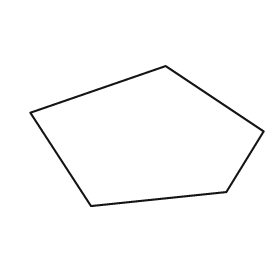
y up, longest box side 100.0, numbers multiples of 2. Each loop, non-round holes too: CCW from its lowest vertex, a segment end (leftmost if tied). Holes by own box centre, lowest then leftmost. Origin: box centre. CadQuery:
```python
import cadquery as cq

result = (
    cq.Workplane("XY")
    .moveTo(-24.0, -30.0)
    .lineTo(34.0, -24.0)
    .lineTo(50.0, 2.0)
    .lineTo(8.0, 30.0)
    .lineTo(-50.0, 10.0)
    .close()
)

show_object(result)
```